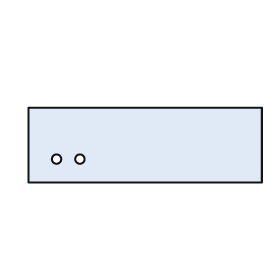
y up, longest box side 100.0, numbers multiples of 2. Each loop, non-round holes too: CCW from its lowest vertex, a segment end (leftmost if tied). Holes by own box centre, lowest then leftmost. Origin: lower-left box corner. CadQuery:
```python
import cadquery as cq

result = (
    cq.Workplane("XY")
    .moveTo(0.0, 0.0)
    .lineTo(100.0, 0.0)
    .lineTo(100.0, 32.0)
    .lineTo(0.0, 32.0)
    .close()
    .moveTo(12.0, 10.0)
    .circle(2.0)
    .moveTo(22.0, 10.0)
    .circle(2.0)
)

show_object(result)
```